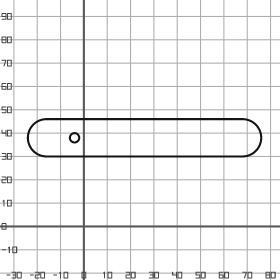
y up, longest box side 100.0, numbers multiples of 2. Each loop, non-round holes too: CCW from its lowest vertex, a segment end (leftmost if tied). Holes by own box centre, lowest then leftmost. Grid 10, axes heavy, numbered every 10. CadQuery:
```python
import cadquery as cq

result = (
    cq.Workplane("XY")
    .moveTo(-16.0, 30.0)
    .lineTo(68.0, 30.0)
    .threePointArc((76.0, 38.0), (68.0, 46.0))
    .lineTo(-16.0, 46.0)
    .threePointArc((-24.0, 38.0), (-16.0, 30.0))
    .close()
    .moveTo(-4.0, 38.0)
    .circle(2.0)
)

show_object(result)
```